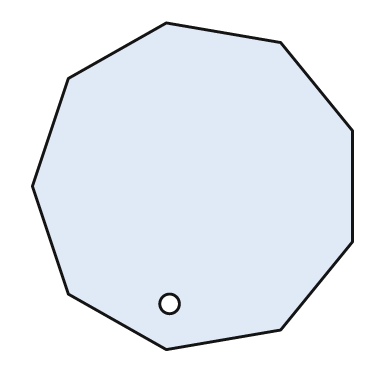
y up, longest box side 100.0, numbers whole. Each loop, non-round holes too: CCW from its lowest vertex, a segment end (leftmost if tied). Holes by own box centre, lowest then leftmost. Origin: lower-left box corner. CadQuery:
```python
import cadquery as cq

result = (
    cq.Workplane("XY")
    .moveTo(41.0, 0.0)
    .lineTo(76.0, 6.0)
    .lineTo(98.0, 33.0)
    .lineTo(98.0, 67.0)
    .lineTo(76.0, 94.0)
    .lineTo(41.0, 100.0)
    .lineTo(11.0, 83.0)
    .lineTo(0.0, 50.0)
    .lineTo(11.0, 17.0)
    .close()
    .moveTo(42.0, 14.0)
    .circle(3.0)
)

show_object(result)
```